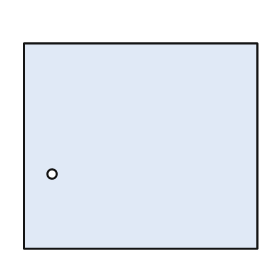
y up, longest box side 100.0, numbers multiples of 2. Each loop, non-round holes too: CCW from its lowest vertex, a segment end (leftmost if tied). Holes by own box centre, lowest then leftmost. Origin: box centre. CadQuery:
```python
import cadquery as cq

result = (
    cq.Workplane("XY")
    .moveTo(-50.0, -44.0)
    .lineTo(50.0, -44.0)
    .lineTo(50.0, 44.0)
    .lineTo(-50.0, 44.0)
    .close()
    .moveTo(-38.0, -12.0)
    .circle(2.0)
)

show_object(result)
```